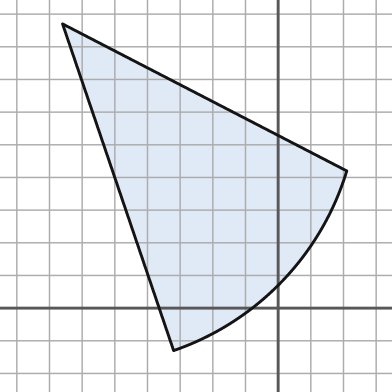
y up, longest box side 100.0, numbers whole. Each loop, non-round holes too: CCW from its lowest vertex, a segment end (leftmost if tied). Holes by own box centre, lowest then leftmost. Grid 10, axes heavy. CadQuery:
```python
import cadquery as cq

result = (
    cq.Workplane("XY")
    .moveTo(-32.0, -13.0)
    .threePointArc((1.0, 8.0), (21.0, 42.0))
    .lineTo(-66.0, 87.0)
    .close()
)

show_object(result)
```